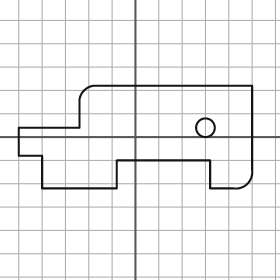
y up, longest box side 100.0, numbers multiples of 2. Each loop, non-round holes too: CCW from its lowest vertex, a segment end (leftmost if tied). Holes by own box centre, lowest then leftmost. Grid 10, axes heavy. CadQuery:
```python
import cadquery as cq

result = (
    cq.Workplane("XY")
    .moveTo(-40.0, -22.0)
    .lineTo(-8.0, -22.0)
    .lineTo(-8.0, -10.0)
    .lineTo(32.0, -10.0)
    .lineTo(32.0, -22.0)
    .lineTo(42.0, -22.0)
    .threePointArc((48.0, -20.0), (50.0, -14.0))
    .lineTo(50.0, 22.0)
    .lineTo(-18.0, 22.0)
    .threePointArc((-22.0, 20.0), (-24.0, 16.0))
    .lineTo(-24.0, 4.0)
    .lineTo(-50.0, 4.0)
    .lineTo(-50.0, -8.0)
    .lineTo(-40.0, -8.0)
    .close()
    .moveTo(30.0, 4.0)
    .circle(4.0)
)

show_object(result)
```